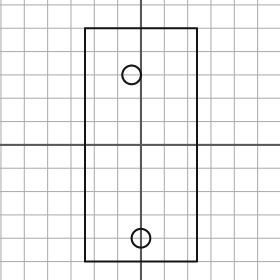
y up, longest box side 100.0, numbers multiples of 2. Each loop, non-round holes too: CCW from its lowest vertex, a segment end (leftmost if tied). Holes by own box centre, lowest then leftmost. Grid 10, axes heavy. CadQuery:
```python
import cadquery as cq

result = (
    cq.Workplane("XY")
    .moveTo(-24.0, -50.0)
    .lineTo(24.0, -50.0)
    .lineTo(24.0, 50.0)
    .lineTo(-24.0, 50.0)
    .close()
    .moveTo(0.0, -40.0)
    .circle(4.0)
    .moveTo(-4.0, 30.0)
    .circle(4.0)
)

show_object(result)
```